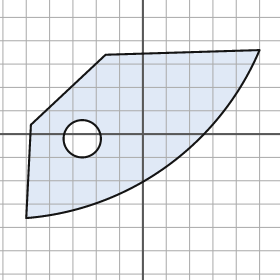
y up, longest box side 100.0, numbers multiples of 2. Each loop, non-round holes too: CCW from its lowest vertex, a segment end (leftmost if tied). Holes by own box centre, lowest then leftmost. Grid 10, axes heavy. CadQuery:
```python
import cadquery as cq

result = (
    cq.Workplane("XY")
    .moveTo(-50.0, -36.0)
    .threePointArc((10.0, -14.0), (50.0, 36.0))
    .lineTo(-16.0, 34.0)
    .lineTo(-48.0, 4.0)
    .close()
    .moveTo(-26.0, -2.0)
    .circle(8.0)
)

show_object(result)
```